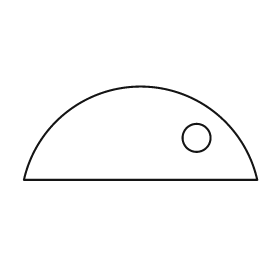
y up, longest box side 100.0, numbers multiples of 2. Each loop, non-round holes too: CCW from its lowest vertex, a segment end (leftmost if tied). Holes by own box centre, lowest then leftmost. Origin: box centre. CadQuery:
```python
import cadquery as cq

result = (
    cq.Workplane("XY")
    .moveTo(-50.0, -20.0)
    .lineTo(50.0, -20.0)
    .threePointArc((0.0, 20.0), (-50.0, -20.0))
    .close()
    .moveTo(24.0, -2.0)
    .circle(6.0)
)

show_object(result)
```